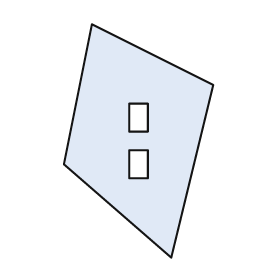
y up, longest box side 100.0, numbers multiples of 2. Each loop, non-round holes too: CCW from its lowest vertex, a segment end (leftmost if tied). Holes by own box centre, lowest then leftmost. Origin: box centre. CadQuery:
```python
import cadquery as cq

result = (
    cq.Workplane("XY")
    .moveTo(14.0, -50.0)
    .lineTo(32.0, 24.0)
    .lineTo(-20.0, 50.0)
    .lineTo(-32.0, -10.0)
    .close()
    .moveTo(-4.0, -16.0)
    .lineTo(4.0, -16.0)
    .lineTo(4.0, -4.0)
    .lineTo(-4.0, -4.0)
    .close()
    .moveTo(-4.0, 4.0)
    .lineTo(4.0, 4.0)
    .lineTo(4.0, 16.0)
    .lineTo(-4.0, 16.0)
    .close()
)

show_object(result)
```